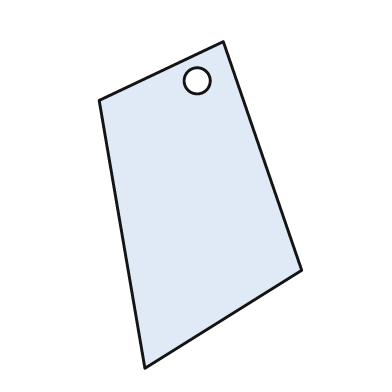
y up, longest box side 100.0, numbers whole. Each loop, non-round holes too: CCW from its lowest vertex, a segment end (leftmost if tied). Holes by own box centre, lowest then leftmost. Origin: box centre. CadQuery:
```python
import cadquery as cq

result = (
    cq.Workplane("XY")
    .moveTo(-17.0, -50.0)
    .lineTo(31.0, -20.0)
    .lineTo(7.0, 50.0)
    .lineTo(-31.0, 32.0)
    .close()
    .moveTo(-1.0, 38.0)
    .circle(4.0)
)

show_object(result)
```